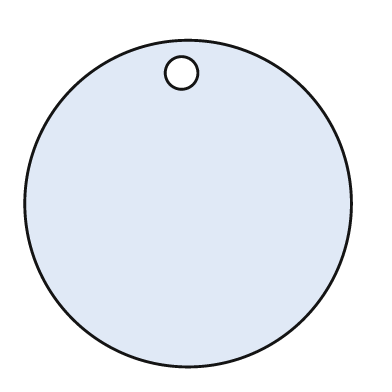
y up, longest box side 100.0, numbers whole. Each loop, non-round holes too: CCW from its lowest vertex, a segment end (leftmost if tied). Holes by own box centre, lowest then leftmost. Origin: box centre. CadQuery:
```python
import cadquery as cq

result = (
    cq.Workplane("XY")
    .moveTo(0.0, 0.0)
    .circle(50.0)
    .moveTo(-2.0, 40.0)
    .circle(5.0)
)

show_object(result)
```